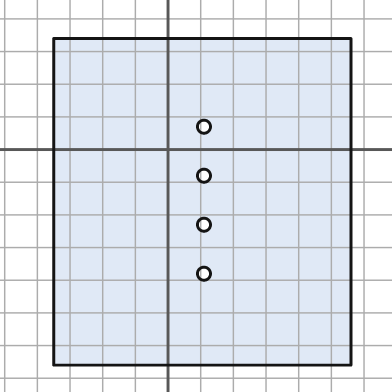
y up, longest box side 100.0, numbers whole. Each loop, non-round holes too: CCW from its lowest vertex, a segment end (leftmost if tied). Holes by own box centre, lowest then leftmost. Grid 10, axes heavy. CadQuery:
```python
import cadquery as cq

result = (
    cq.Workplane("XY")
    .moveTo(-35.0, -66.0)
    .lineTo(56.0, -66.0)
    .lineTo(56.0, 34.0)
    .lineTo(-35.0, 34.0)
    .close()
    .moveTo(11.0, -38.0)
    .circle(2.0)
    .moveTo(11.0, -23.0)
    .circle(2.0)
    .moveTo(11.0, -8.0)
    .circle(2.0)
    .moveTo(11.0, 7.0)
    .circle(2.0)
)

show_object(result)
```